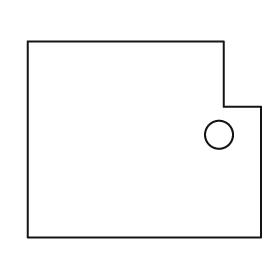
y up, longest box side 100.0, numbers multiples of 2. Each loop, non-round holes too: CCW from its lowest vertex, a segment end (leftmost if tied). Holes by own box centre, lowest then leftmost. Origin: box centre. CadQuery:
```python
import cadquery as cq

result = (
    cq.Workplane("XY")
    .moveTo(-50.0, -42.0)
    .lineTo(50.0, -42.0)
    .lineTo(50.0, 14.0)
    .lineTo(34.0, 14.0)
    .lineTo(34.0, 42.0)
    .lineTo(-50.0, 42.0)
    .close()
    .moveTo(32.0, 2.0)
    .circle(6.0)
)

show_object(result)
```